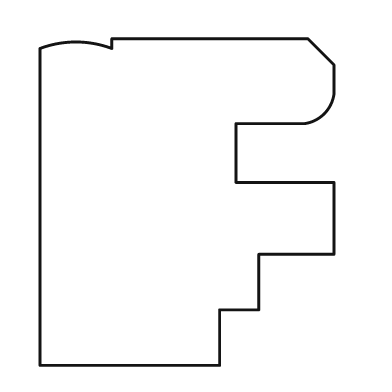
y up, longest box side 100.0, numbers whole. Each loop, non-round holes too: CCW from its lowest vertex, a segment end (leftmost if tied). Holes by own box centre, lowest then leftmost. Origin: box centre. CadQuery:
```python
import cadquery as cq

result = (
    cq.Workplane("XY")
    .moveTo(-45.0, -50.0)
    .lineTo(10.0, -50.0)
    .lineTo(10.0, -33.0)
    .lineTo(22.0, -33.0)
    .lineTo(22.0, -16.0)
    .lineTo(45.0, -16.0)
    .lineTo(45.0, 6.0)
    .lineTo(15.0, 6.0)
    .lineTo(15.0, 24.0)
    .lineTo(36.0, 24.0)
    .threePointArc((42.0, 27.0), (45.0, 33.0))
    .lineTo(45.0, 42.0)
    .lineTo(37.0, 50.0)
    .lineTo(-23.0, 50.0)
    .lineTo(-23.0, 47.0)
    .threePointArc((-34.0, 49.0), (-45.0, 47.0))
    .close()
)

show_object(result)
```